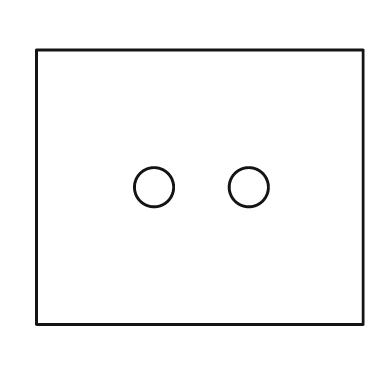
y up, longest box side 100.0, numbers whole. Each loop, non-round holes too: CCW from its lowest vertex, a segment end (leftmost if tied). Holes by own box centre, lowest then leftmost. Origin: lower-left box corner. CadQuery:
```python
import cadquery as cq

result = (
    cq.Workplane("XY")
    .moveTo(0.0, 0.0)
    .lineTo(100.0, 0.0)
    .lineTo(100.0, 84.0)
    .lineTo(0.0, 84.0)
    .close()
    .moveTo(36.0, 42.0)
    .circle(6.0)
    .moveTo(65.0, 42.0)
    .circle(6.0)
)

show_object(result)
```